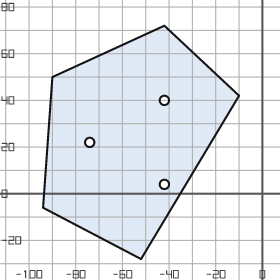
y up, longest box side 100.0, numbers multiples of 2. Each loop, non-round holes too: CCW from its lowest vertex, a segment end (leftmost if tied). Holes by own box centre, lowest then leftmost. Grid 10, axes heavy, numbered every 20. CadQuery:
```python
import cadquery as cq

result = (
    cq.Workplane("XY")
    .moveTo(-52.0, -28.0)
    .lineTo(-10.0, 42.0)
    .lineTo(-42.0, 72.0)
    .lineTo(-90.0, 50.0)
    .lineTo(-94.0, -6.0)
    .close()
    .moveTo(-42.0, 4.0)
    .circle(2.0)
    .moveTo(-74.0, 22.0)
    .circle(2.0)
    .moveTo(-42.0, 40.0)
    .circle(2.0)
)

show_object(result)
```